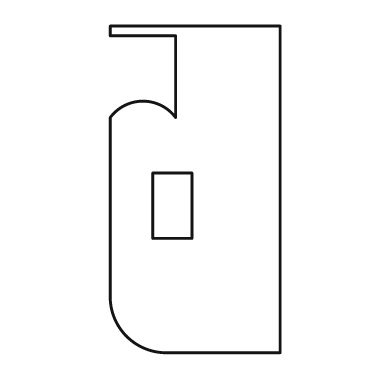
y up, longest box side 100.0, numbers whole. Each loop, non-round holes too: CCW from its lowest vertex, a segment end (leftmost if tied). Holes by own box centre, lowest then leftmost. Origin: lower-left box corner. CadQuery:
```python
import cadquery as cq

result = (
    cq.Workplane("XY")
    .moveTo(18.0, 0.0)
    .lineTo(52.0, 0.0)
    .lineTo(52.0, 100.0)
    .lineTo(0.0, 100.0)
    .lineTo(0.0, 97.0)
    .lineTo(20.0, 97.0)
    .lineTo(20.0, 72.0)
    .threePointArc((10.0, 77.0), (0.0, 72.0))
    .lineTo(0.0, 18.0)
    .threePointArc((5.0, 5.0), (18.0, 0.0))
    .close()
    .moveTo(13.0, 35.0)
    .lineTo(25.0, 35.0)
    .lineTo(25.0, 55.0)
    .lineTo(13.0, 55.0)
    .close()
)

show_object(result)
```